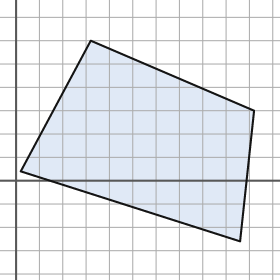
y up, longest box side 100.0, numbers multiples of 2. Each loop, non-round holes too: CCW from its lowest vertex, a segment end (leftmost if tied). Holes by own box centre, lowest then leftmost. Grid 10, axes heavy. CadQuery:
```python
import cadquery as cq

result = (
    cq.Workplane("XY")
    .moveTo(96.0, -26.0)
    .lineTo(102.0, 30.0)
    .lineTo(32.0, 60.0)
    .lineTo(2.0, 4.0)
    .close()
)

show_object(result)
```